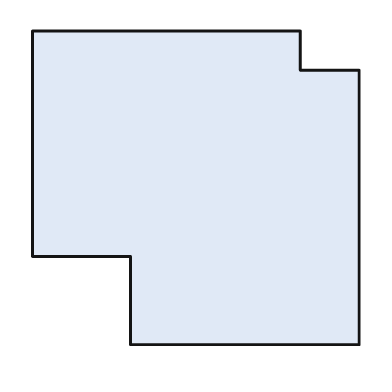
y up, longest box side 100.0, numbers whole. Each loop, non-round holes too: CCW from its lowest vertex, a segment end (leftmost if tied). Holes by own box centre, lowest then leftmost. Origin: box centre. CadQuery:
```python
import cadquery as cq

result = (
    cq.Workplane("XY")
    .moveTo(-20.0, -48.0)
    .lineTo(50.0, -48.0)
    .lineTo(50.0, 36.0)
    .lineTo(32.0, 36.0)
    .lineTo(32.0, 48.0)
    .lineTo(-50.0, 48.0)
    .lineTo(-50.0, -21.0)
    .lineTo(-20.0, -21.0)
    .close()
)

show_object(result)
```